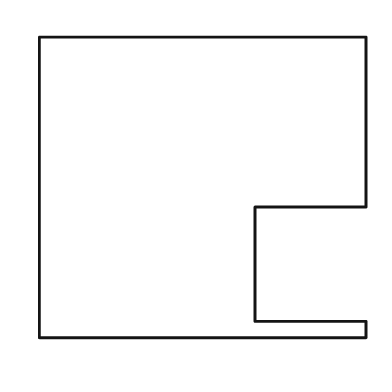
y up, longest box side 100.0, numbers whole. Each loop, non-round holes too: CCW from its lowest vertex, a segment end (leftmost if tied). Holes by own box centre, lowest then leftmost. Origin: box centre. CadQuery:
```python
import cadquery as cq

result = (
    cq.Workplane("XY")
    .moveTo(-50.0, -46.0)
    .lineTo(50.0, -46.0)
    .lineTo(50.0, -41.0)
    .lineTo(16.0, -41.0)
    .lineTo(16.0, -6.0)
    .lineTo(50.0, -6.0)
    .lineTo(50.0, 46.0)
    .lineTo(-50.0, 46.0)
    .close()
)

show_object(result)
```